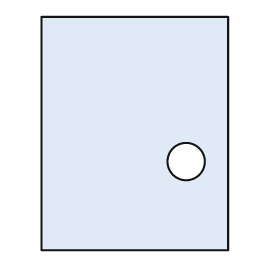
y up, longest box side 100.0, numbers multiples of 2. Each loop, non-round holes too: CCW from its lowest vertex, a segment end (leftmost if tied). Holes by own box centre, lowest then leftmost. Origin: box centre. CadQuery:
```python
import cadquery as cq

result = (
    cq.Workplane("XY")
    .moveTo(-40.0, -50.0)
    .lineTo(40.0, -50.0)
    .lineTo(40.0, 50.0)
    .lineTo(-40.0, 50.0)
    .close()
    .moveTo(22.0, -12.0)
    .circle(8.0)
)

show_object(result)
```